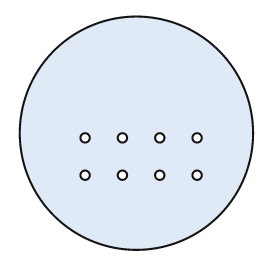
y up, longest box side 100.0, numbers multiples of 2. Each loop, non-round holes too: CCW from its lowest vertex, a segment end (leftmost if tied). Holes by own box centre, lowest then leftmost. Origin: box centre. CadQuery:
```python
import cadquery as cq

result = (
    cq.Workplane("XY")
    .moveTo(0.0, 0.0)
    .circle(50.0)
    .moveTo(-22.0, -18.0)
    .circle(2.0)
    .moveTo(-6.0, -18.0)
    .circle(2.0)
    .moveTo(10.0, -18.0)
    .circle(2.0)
    .moveTo(26.0, -18.0)
    .circle(2.0)
    .moveTo(-22.0, -2.0)
    .circle(2.0)
    .moveTo(-6.0, -2.0)
    .circle(2.0)
    .moveTo(10.0, -2.0)
    .circle(2.0)
    .moveTo(26.0, -2.0)
    .circle(2.0)
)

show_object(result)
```